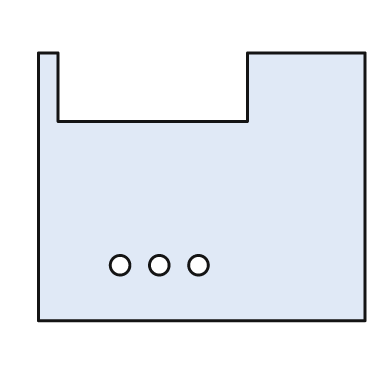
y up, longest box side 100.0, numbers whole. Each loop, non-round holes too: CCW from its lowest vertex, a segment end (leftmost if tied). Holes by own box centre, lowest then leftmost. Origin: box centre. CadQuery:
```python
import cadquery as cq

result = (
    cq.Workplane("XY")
    .moveTo(-50.0, -41.0)
    .lineTo(50.0, -41.0)
    .lineTo(50.0, 41.0)
    .lineTo(14.0, 41.0)
    .lineTo(14.0, 20.0)
    .lineTo(-44.0, 20.0)
    .lineTo(-44.0, 41.0)
    .lineTo(-50.0, 41.0)
    .close()
    .moveTo(-25.0, -24.0)
    .circle(3.0)
    .moveTo(-13.0, -24.0)
    .circle(3.0)
    .moveTo(-1.0, -24.0)
    .circle(3.0)
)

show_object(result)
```